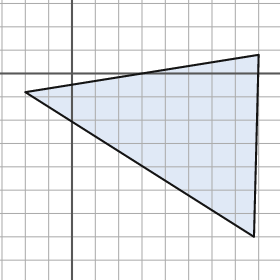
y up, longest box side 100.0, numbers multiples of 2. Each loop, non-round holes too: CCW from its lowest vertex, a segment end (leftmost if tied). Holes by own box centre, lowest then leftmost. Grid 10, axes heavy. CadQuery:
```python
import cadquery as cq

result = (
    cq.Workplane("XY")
    .moveTo(78.0, -70.0)
    .lineTo(80.0, 8.0)
    .lineTo(-20.0, -8.0)
    .close()
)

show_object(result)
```